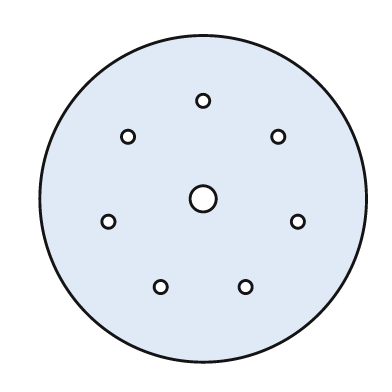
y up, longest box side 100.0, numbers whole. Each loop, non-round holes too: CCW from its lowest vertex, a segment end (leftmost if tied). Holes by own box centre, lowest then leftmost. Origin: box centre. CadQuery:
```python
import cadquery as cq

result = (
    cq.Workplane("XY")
    .moveTo(0.0, 0.0)
    .circle(50.0)
    .moveTo(-13.0, -27.0)
    .circle(2.0)
    .moveTo(13.0, -27.0)
    .circle(2.0)
    .moveTo(-29.0, -7.0)
    .circle(2.0)
    .moveTo(29.0, -7.0)
    .circle(2.0)
    .moveTo(0.0, 0.0)
    .circle(4.0)
    .moveTo(-23.0, 19.0)
    .circle(2.0)
    .moveTo(23.0, 19.0)
    .circle(2.0)
    .moveTo(0.0, 30.0)
    .circle(2.0)
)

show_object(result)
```